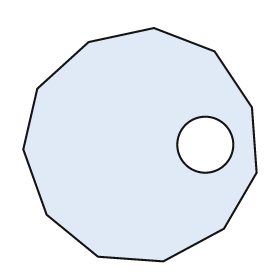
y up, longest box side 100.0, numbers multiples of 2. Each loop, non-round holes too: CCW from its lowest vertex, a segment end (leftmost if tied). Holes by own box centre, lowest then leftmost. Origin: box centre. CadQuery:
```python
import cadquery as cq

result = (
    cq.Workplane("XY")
    .moveTo(10.0, -50.0)
    .lineTo(36.0, -36.0)
    .lineTo(50.0, -12.0)
    .lineTo(48.0, 16.0)
    .lineTo(32.0, 40.0)
    .lineTo(6.0, 50.0)
    .lineTo(-22.0, 44.0)
    .lineTo(-44.0, 24.0)
    .lineTo(-50.0, -2.0)
    .lineTo(-40.0, -30.0)
    .lineTo(-18.0, -48.0)
    .close()
    .moveTo(28.0, 0.0)
    .circle(12.0)
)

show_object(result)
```